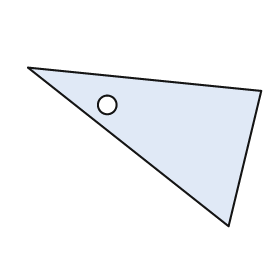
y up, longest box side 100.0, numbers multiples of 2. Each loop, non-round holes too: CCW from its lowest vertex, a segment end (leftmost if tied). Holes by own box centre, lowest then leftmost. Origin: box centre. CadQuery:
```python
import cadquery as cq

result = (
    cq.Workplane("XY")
    .moveTo(36.0, -34.0)
    .lineTo(50.0, 24.0)
    .lineTo(-50.0, 34.0)
    .close()
    .moveTo(-16.0, 18.0)
    .circle(4.0)
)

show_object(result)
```